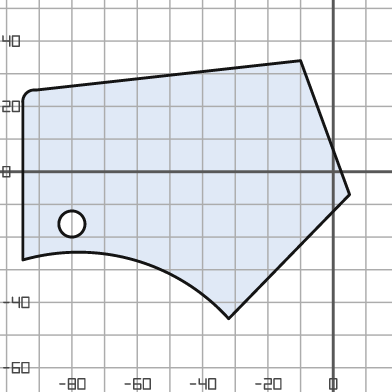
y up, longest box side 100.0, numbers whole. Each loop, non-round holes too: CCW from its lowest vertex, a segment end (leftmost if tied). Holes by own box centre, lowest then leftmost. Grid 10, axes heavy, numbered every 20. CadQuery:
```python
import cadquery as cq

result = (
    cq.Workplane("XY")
    .moveTo(-32.0, -45.0)
    .lineTo(5.0, -7.0)
    .lineTo(-10.0, 34.0)
    .lineTo(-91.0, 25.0)
    .threePointArc((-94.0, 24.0), (-95.0, 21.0))
    .lineTo(-95.0, -27.0)
    .threePointArc((-61.0, -27.0), (-32.0, -45.0))
    .close()
    .moveTo(-80.0, -16.0)
    .circle(4.0)
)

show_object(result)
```